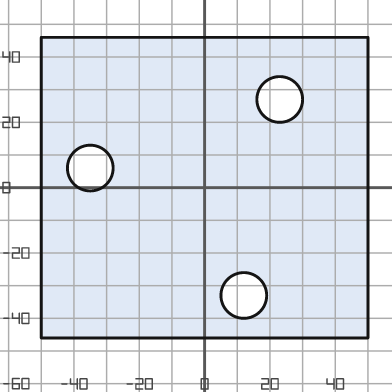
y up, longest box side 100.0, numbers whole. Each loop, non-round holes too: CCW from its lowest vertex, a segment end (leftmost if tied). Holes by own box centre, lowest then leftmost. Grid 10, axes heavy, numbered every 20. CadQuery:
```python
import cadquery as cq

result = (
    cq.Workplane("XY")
    .moveTo(-50.0, -46.0)
    .lineTo(50.0, -46.0)
    .lineTo(50.0, 46.0)
    .lineTo(-50.0, 46.0)
    .close()
    .moveTo(12.0, -33.0)
    .circle(7.0)
    .moveTo(-35.0, 6.0)
    .circle(7.0)
    .moveTo(23.0, 27.0)
    .circle(7.0)
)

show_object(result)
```